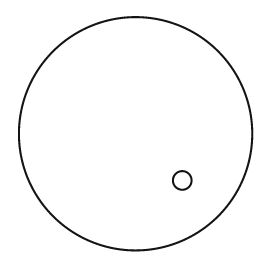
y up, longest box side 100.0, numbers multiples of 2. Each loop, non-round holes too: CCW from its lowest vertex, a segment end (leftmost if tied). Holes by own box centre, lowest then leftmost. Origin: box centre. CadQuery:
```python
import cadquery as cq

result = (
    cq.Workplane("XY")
    .moveTo(0.0, 0.0)
    .circle(50.0)
    .moveTo(20.0, -20.0)
    .circle(4.0)
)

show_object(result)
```